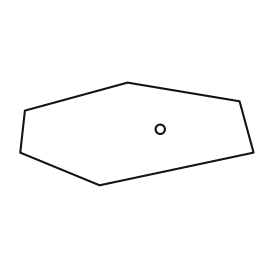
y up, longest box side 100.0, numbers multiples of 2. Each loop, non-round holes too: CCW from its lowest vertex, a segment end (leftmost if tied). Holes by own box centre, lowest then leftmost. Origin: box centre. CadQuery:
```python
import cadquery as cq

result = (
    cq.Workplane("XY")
    .moveTo(-16.0, -22.0)
    .lineTo(50.0, -8.0)
    .lineTo(44.0, 14.0)
    .lineTo(-4.0, 22.0)
    .lineTo(-48.0, 10.0)
    .lineTo(-50.0, -8.0)
    .close()
    .moveTo(10.0, 2.0)
    .circle(2.0)
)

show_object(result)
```